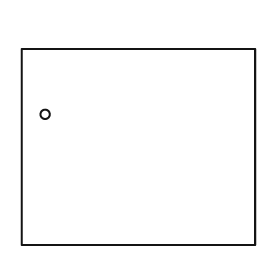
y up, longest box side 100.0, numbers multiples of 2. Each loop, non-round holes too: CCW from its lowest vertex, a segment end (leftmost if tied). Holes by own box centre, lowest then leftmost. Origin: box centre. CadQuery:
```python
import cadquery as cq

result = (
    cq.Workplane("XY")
    .moveTo(-50.0, -42.0)
    .lineTo(50.0, -42.0)
    .lineTo(50.0, 42.0)
    .lineTo(-50.0, 42.0)
    .close()
    .moveTo(-40.0, 14.0)
    .circle(2.0)
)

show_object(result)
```